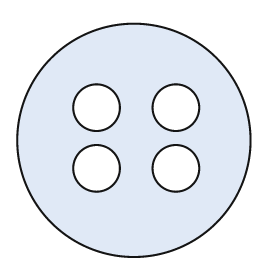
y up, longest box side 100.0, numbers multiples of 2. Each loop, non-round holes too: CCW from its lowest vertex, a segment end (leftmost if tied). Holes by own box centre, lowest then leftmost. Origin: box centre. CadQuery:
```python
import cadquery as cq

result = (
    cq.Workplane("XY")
    .moveTo(0.0, 0.0)
    .circle(50.0)
    .moveTo(-16.0, -12.0)
    .circle(10.0)
    .moveTo(18.0, -12.0)
    .circle(10.0)
    .moveTo(-16.0, 14.0)
    .circle(10.0)
    .moveTo(18.0, 14.0)
    .circle(10.0)
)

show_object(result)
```